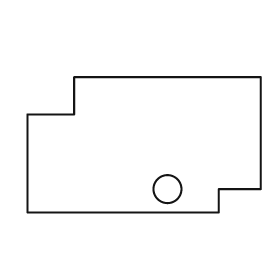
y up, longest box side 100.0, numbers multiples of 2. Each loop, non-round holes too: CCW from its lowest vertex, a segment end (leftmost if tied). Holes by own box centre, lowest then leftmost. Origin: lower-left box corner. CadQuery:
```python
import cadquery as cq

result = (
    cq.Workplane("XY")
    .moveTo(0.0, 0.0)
    .lineTo(82.0, 0.0)
    .lineTo(82.0, 10.0)
    .lineTo(100.0, 10.0)
    .lineTo(100.0, 58.0)
    .lineTo(20.0, 58.0)
    .lineTo(20.0, 42.0)
    .lineTo(0.0, 42.0)
    .close()
    .moveTo(60.0, 10.0)
    .circle(6.0)
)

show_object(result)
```